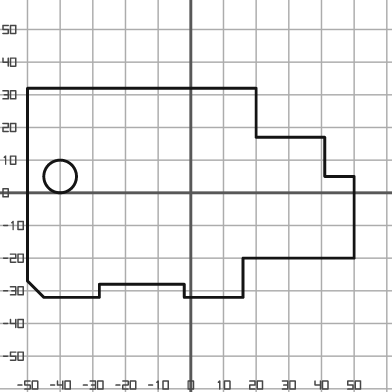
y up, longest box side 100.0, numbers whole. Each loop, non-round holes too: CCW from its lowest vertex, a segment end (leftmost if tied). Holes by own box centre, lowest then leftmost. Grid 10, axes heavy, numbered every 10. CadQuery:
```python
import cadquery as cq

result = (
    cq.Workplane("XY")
    .moveTo(-45.0, -32.0)
    .lineTo(-28.0, -32.0)
    .lineTo(-28.0, -28.0)
    .lineTo(-2.0, -28.0)
    .lineTo(-2.0, -32.0)
    .lineTo(16.0, -32.0)
    .lineTo(16.0, -20.0)
    .lineTo(50.0, -20.0)
    .lineTo(50.0, 5.0)
    .lineTo(41.0, 5.0)
    .lineTo(41.0, 17.0)
    .lineTo(20.0, 17.0)
    .lineTo(20.0, 32.0)
    .lineTo(-50.0, 32.0)
    .lineTo(-50.0, -27.0)
    .close()
    .moveTo(-40.0, 5.0)
    .circle(5.0)
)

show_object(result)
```